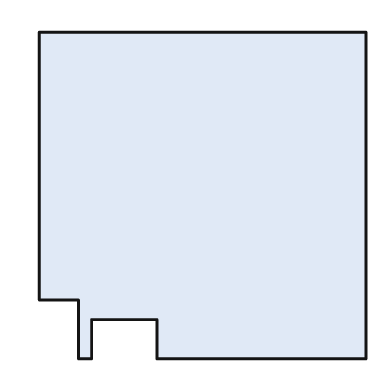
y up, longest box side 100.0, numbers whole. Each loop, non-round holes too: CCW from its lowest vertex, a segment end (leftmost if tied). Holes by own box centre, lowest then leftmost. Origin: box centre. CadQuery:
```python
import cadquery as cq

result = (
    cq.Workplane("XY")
    .moveTo(-38.0, -50.0)
    .lineTo(-34.0, -50.0)
    .lineTo(-34.0, -38.0)
    .lineTo(-14.0, -38.0)
    .lineTo(-14.0, -50.0)
    .lineTo(50.0, -50.0)
    .lineTo(50.0, 50.0)
    .lineTo(-50.0, 50.0)
    .lineTo(-50.0, -32.0)
    .lineTo(-38.0, -32.0)
    .close()
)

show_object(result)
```